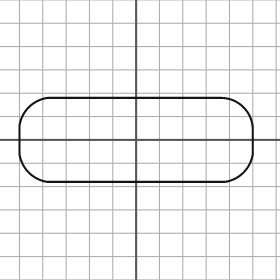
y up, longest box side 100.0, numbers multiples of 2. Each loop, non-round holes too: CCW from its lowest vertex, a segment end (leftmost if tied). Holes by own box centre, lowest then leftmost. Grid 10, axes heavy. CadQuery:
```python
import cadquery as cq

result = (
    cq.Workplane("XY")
    .moveTo(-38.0, -18.0)
    .lineTo(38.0, -18.0)
    .threePointArc((46.0, -14.0), (50.0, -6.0))
    .lineTo(50.0, 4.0)
    .threePointArc((46.0, 14.0), (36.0, 18.0))
    .lineTo(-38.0, 18.0)
    .threePointArc((-46.0, 14.0), (-50.0, 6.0))
    .lineTo(-50.0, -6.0)
    .threePointArc((-46.0, -14.0), (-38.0, -18.0))
    .close()
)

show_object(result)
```